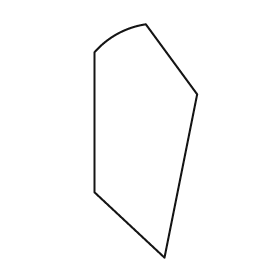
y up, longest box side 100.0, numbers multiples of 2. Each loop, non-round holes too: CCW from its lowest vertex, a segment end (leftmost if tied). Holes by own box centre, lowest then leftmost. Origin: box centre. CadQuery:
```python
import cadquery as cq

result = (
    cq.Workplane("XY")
    .moveTo(8.0, -50.0)
    .lineTo(22.0, 20.0)
    .lineTo(0.0, 50.0)
    .threePointArc((-12.0, 46.0), (-22.0, 38.0))
    .lineTo(-22.0, -22.0)
    .close()
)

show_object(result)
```